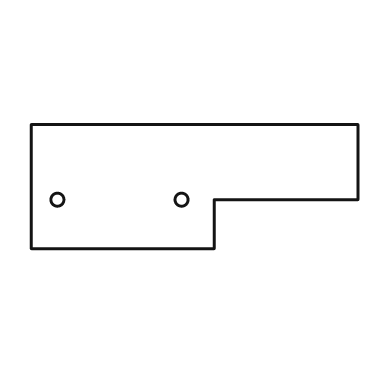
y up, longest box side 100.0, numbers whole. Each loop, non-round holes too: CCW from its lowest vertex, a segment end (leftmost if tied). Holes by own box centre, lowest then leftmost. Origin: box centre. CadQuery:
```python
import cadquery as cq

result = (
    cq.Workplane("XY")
    .moveTo(-50.0, -19.0)
    .lineTo(6.0, -19.0)
    .lineTo(6.0, -4.0)
    .lineTo(50.0, -4.0)
    .lineTo(50.0, 19.0)
    .lineTo(-50.0, 19.0)
    .close()
    .moveTo(-42.0, -4.0)
    .circle(2.0)
    .moveTo(-4.0, -4.0)
    .circle(2.0)
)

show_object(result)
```